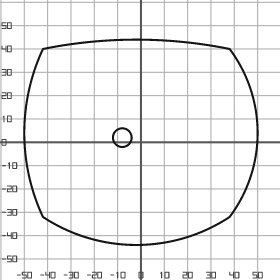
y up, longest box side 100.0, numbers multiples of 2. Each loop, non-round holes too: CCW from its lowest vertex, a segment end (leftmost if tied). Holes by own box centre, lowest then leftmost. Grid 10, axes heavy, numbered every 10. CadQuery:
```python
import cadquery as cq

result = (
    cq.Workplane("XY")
    .moveTo(-42.0, -32.0)
    .threePointArc((-2.0, -44.0), (38.0, -32.0))
    .threePointArc((50.0, 4.0), (38.0, 40.0))
    .threePointArc((-2.0, 44.0), (-42.0, 40.0))
    .threePointArc((-50.0, 4.0), (-42.0, -32.0))
    .close()
    .moveTo(-8.0, 2.0)
    .circle(4.0)
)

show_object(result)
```